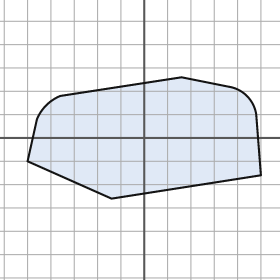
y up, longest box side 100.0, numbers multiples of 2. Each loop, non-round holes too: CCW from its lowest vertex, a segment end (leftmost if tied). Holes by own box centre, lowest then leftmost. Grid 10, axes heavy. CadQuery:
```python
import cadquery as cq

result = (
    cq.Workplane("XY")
    .moveTo(-14.0, -26.0)
    .lineTo(50.0, -16.0)
    .lineTo(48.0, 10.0)
    .threePointArc((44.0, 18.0), (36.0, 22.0))
    .lineTo(16.0, 26.0)
    .lineTo(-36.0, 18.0)
    .threePointArc((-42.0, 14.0), (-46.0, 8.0))
    .lineTo(-50.0, -10.0)
    .close()
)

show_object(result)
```